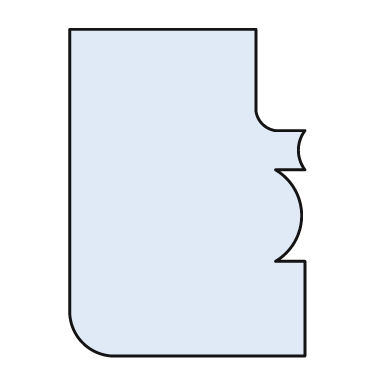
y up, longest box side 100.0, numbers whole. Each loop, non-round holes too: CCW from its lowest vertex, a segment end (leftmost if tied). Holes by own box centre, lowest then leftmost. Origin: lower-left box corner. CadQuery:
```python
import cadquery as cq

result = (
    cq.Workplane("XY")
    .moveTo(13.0, 0.0)
    .lineTo(72.0, 0.0)
    .lineTo(72.0, 29.0)
    .lineTo(63.0, 29.0)
    .threePointArc((71.0, 43.0), (63.0, 57.0))
    .lineTo(72.0, 57.0)
    .threePointArc((70.0, 63.0), (72.0, 69.0))
    .lineTo(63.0, 69.0)
    .threePointArc((59.0, 71.0), (57.0, 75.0))
    .lineTo(57.0, 100.0)
    .lineTo(0.0, 100.0)
    .lineTo(0.0, 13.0)
    .threePointArc((4.0, 4.0), (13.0, 0.0))
    .close()
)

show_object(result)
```